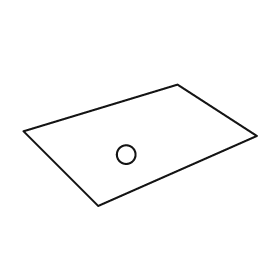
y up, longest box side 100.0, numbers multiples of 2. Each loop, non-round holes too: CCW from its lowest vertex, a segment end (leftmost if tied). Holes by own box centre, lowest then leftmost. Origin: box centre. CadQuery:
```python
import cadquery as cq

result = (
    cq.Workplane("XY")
    .moveTo(-18.0, -26.0)
    .lineTo(50.0, 4.0)
    .lineTo(16.0, 26.0)
    .lineTo(-50.0, 6.0)
    .close()
    .moveTo(-6.0, -4.0)
    .circle(4.0)
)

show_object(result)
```